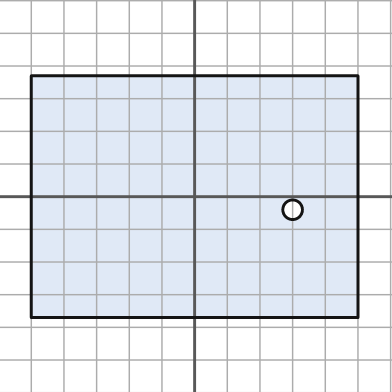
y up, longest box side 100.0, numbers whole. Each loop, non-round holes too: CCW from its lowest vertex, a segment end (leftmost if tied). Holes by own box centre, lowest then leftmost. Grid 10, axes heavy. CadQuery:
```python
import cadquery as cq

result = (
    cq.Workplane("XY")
    .moveTo(-50.0, -37.0)
    .lineTo(50.0, -37.0)
    .lineTo(50.0, 37.0)
    .lineTo(-50.0, 37.0)
    .close()
    .moveTo(30.0, -4.0)
    .circle(3.0)
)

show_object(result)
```